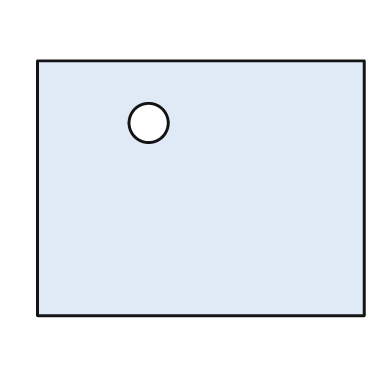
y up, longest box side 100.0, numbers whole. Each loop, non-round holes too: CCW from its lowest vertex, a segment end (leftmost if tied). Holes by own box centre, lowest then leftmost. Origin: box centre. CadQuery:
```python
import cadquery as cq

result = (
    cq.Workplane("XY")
    .moveTo(-50.0, -39.0)
    .lineTo(50.0, -39.0)
    .lineTo(50.0, 39.0)
    .lineTo(-50.0, 39.0)
    .close()
    .moveTo(-16.0, 20.0)
    .circle(6.0)
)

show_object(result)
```